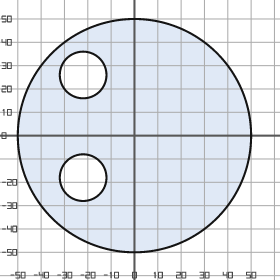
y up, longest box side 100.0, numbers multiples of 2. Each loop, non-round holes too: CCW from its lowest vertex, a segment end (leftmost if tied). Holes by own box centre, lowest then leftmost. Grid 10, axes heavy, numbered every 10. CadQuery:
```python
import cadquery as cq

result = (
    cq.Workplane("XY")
    .moveTo(0.0, 0.0)
    .circle(50.0)
    .moveTo(-22.0, -18.0)
    .circle(10.0)
    .moveTo(-22.0, 26.0)
    .circle(10.0)
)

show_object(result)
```